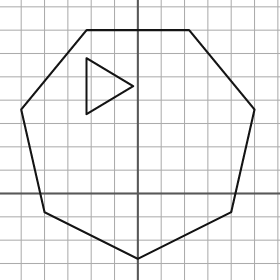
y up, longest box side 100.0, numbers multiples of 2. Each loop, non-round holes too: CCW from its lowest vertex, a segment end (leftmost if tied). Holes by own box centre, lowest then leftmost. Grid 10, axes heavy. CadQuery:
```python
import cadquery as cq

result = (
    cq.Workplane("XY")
    .moveTo(0.0, -28.0)
    .lineTo(40.0, -8.0)
    .lineTo(50.0, 36.0)
    .lineTo(22.0, 70.0)
    .lineTo(-22.0, 70.0)
    .lineTo(-50.0, 36.0)
    .lineTo(-40.0, -8.0)
    .close()
    .moveTo(-22.0, 34.0)
    .lineTo(-2.0, 46.0)
    .lineTo(-22.0, 58.0)
    .close()
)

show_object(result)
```